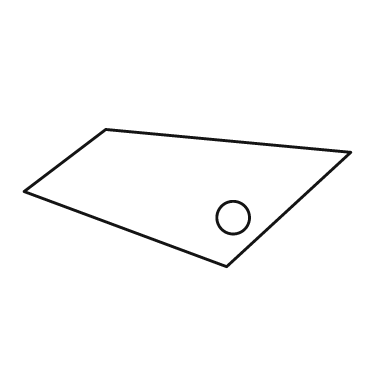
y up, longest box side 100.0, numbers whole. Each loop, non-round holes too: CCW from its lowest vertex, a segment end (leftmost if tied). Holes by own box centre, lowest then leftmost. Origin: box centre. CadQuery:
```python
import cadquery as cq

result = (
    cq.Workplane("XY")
    .moveTo(12.0, -21.0)
    .lineTo(50.0, 14.0)
    .lineTo(-25.0, 21.0)
    .lineTo(-50.0, 2.0)
    .close()
    .moveTo(14.0, -6.0)
    .circle(5.0)
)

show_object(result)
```